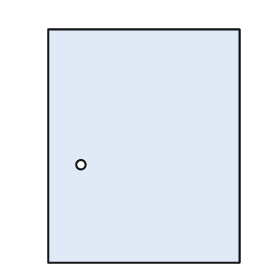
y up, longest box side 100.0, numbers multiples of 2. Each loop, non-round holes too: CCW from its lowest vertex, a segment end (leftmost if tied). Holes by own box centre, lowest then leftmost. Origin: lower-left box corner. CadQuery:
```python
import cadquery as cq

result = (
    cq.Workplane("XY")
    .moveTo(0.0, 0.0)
    .lineTo(82.0, 0.0)
    .lineTo(82.0, 100.0)
    .lineTo(0.0, 100.0)
    .close()
    .moveTo(14.0, 42.0)
    .circle(2.0)
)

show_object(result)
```